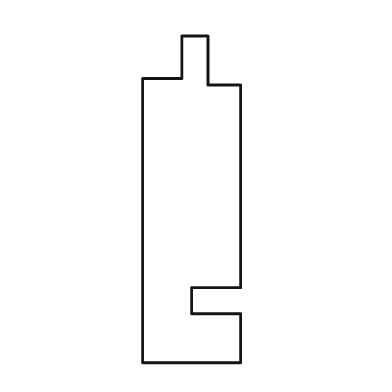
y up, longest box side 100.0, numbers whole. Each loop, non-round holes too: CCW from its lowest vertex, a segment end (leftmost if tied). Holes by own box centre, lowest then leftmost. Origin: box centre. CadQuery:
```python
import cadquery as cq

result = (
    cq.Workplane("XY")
    .moveTo(-15.0, -50.0)
    .lineTo(15.0, -50.0)
    .lineTo(15.0, -35.0)
    .lineTo(0.0, -35.0)
    .lineTo(0.0, -27.0)
    .lineTo(15.0, -27.0)
    .lineTo(15.0, 35.0)
    .lineTo(5.0, 35.0)
    .lineTo(5.0, 50.0)
    .lineTo(-3.0, 50.0)
    .lineTo(-3.0, 37.0)
    .lineTo(-15.0, 37.0)
    .close()
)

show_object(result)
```